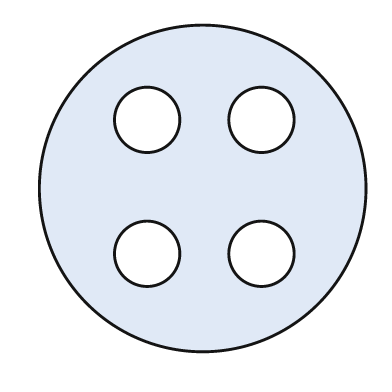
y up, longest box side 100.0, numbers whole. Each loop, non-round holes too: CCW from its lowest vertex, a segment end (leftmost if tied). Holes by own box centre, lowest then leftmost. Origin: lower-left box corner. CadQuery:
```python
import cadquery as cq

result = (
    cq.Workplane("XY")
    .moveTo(50.0, 50.0)
    .circle(50.0)
    .moveTo(33.0, 30.0)
    .circle(10.0)
    .moveTo(68.0, 30.0)
    .circle(10.0)
    .moveTo(33.0, 71.0)
    .circle(10.0)
    .moveTo(68.0, 71.0)
    .circle(10.0)
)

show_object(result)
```